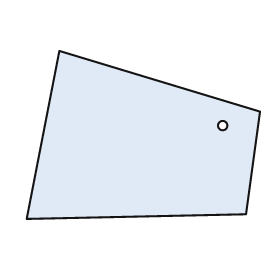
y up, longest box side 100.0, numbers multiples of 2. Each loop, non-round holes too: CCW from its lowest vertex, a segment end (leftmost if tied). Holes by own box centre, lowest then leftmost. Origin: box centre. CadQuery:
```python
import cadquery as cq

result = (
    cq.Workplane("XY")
    .moveTo(-50.0, -36.0)
    .lineTo(44.0, -34.0)
    .lineTo(50.0, 10.0)
    .lineTo(-36.0, 36.0)
    .close()
    .moveTo(34.0, 4.0)
    .circle(2.0)
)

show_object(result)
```